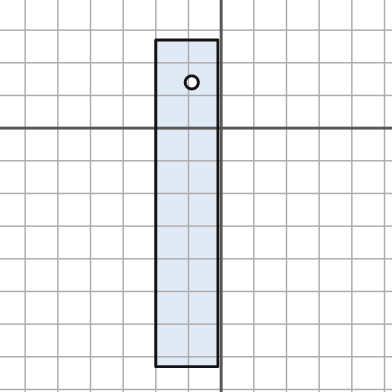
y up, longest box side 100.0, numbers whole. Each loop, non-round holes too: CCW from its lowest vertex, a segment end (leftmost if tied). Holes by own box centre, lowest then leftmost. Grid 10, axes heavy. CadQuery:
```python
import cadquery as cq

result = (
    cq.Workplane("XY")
    .moveTo(-20.0, -73.0)
    .lineTo(-1.0, -73.0)
    .lineTo(-1.0, 27.0)
    .lineTo(-20.0, 27.0)
    .close()
    .moveTo(-9.0, 14.0)
    .circle(2.0)
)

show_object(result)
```